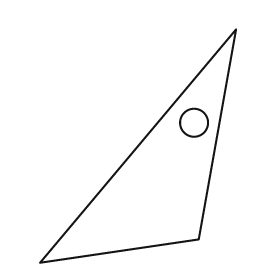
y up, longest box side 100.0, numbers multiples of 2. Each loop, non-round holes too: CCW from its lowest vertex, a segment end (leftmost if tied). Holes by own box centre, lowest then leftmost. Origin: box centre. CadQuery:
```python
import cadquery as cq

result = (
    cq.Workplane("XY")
    .moveTo(-42.0, -50.0)
    .lineTo(26.0, -40.0)
    .lineTo(42.0, 50.0)
    .close()
    .moveTo(24.0, 10.0)
    .circle(6.0)
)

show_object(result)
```